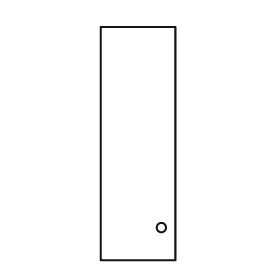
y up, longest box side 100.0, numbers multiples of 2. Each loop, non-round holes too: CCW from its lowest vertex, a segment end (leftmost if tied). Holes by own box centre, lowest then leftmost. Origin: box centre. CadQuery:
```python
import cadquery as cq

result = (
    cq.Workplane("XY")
    .moveTo(-16.0, -50.0)
    .lineTo(16.0, -50.0)
    .lineTo(16.0, 50.0)
    .lineTo(-16.0, 50.0)
    .close()
    .moveTo(10.0, -36.0)
    .circle(2.0)
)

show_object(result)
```